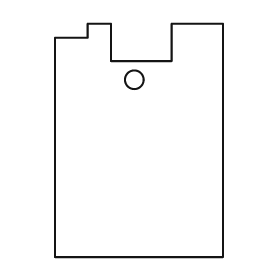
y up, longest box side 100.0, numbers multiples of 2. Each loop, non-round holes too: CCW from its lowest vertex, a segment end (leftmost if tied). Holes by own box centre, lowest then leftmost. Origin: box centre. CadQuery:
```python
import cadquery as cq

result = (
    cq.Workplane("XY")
    .moveTo(-36.0, -50.0)
    .lineTo(36.0, -50.0)
    .lineTo(36.0, 50.0)
    .lineTo(14.0, 50.0)
    .lineTo(14.0, 34.0)
    .lineTo(-12.0, 34.0)
    .lineTo(-12.0, 50.0)
    .lineTo(-22.0, 50.0)
    .lineTo(-22.0, 44.0)
    .lineTo(-36.0, 44.0)
    .close()
    .moveTo(-2.0, 26.0)
    .circle(4.0)
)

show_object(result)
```